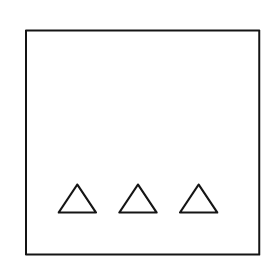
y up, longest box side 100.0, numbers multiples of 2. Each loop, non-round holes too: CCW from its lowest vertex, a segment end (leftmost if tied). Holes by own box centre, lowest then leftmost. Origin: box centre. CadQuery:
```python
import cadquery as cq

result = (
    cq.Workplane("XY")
    .moveTo(-50.0, -48.0)
    .lineTo(50.0, -48.0)
    .lineTo(50.0, 48.0)
    .lineTo(-50.0, 48.0)
    .close()
    .moveTo(-36.0, -30.0)
    .lineTo(-20.0, -30.0)
    .lineTo(-28.0, -18.0)
    .close()
    .moveTo(-10.0, -30.0)
    .lineTo(6.0, -30.0)
    .lineTo(-2.0, -18.0)
    .close()
    .moveTo(16.0, -30.0)
    .lineTo(32.0, -30.0)
    .lineTo(24.0, -18.0)
    .close()
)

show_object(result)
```